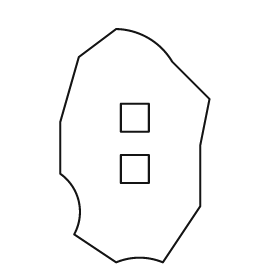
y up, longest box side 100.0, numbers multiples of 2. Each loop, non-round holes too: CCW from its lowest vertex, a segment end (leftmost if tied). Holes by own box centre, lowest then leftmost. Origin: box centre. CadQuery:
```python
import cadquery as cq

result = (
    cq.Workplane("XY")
    .moveTo(-8.0, -50.0)
    .threePointArc((2.0, -48.0), (12.0, -50.0))
    .lineTo(28.0, -26.0)
    .lineTo(28.0, 0.0)
    .lineTo(32.0, 20.0)
    .lineTo(16.0, 36.0)
    .threePointArc((6.0, 46.0), (-8.0, 50.0))
    .lineTo(-24.0, 38.0)
    .lineTo(-32.0, 10.0)
    .lineTo(-32.0, -12.0)
    .threePointArc((-24.0, -24.0), (-26.0, -38.0))
    .close()
    .moveTo(-6.0, -16.0)
    .lineTo(6.0, -16.0)
    .lineTo(6.0, -4.0)
    .lineTo(-6.0, -4.0)
    .close()
    .moveTo(-6.0, 6.0)
    .lineTo(6.0, 6.0)
    .lineTo(6.0, 18.0)
    .lineTo(-6.0, 18.0)
    .close()
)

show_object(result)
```